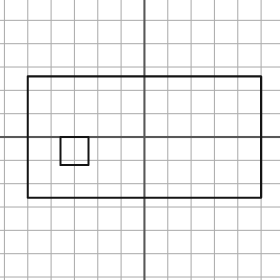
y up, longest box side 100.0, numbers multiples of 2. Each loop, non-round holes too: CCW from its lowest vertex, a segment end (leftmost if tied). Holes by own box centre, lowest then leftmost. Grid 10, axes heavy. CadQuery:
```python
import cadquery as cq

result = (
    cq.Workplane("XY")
    .moveTo(-50.0, -26.0)
    .lineTo(50.0, -26.0)
    .lineTo(50.0, 26.0)
    .lineTo(-50.0, 26.0)
    .close()
    .moveTo(-36.0, -12.0)
    .lineTo(-24.0, -12.0)
    .lineTo(-24.0, 0.0)
    .lineTo(-36.0, 0.0)
    .close()
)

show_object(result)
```